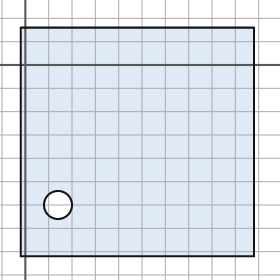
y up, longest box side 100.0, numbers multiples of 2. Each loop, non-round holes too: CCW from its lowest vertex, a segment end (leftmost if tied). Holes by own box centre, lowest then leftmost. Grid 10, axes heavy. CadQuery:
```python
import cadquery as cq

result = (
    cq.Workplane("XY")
    .moveTo(-2.0, -82.0)
    .lineTo(98.0, -82.0)
    .lineTo(98.0, 16.0)
    .lineTo(-2.0, 16.0)
    .close()
    .moveTo(14.0, -60.0)
    .circle(6.0)
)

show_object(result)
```